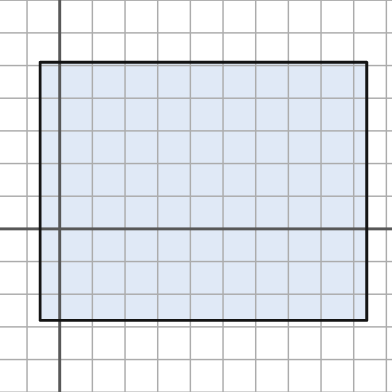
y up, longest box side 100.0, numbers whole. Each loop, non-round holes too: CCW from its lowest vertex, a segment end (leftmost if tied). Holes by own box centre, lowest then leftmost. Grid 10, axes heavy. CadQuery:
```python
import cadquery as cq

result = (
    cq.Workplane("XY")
    .moveTo(-6.0, -28.0)
    .lineTo(94.0, -28.0)
    .lineTo(94.0, 51.0)
    .lineTo(-6.0, 51.0)
    .close()
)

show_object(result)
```